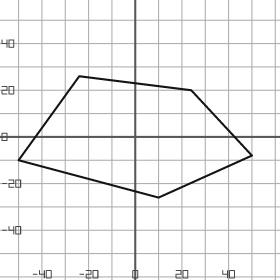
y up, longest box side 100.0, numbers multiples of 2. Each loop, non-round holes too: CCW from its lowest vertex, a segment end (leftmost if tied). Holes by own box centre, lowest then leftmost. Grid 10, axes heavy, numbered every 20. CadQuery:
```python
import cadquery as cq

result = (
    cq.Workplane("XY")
    .moveTo(10.0, -26.0)
    .lineTo(50.0, -8.0)
    .lineTo(24.0, 20.0)
    .lineTo(-24.0, 26.0)
    .lineTo(-50.0, -10.0)
    .close()
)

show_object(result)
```